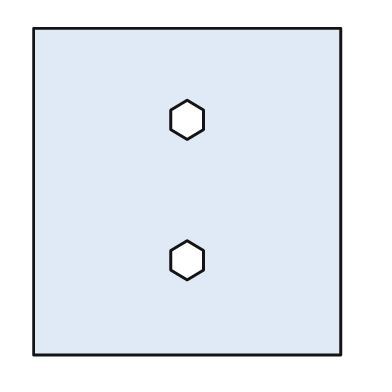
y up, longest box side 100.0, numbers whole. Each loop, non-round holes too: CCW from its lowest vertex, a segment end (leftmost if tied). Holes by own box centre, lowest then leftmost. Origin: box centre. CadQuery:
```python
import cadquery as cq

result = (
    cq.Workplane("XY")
    .moveTo(-47.0, -50.0)
    .lineTo(47.0, -50.0)
    .lineTo(47.0, 50.0)
    .lineTo(-47.0, 50.0)
    .close()
    .moveTo(0.0, -27.0)
    .lineTo(5.0, -24.0)
    .lineTo(5.0, -18.0)
    .lineTo(0.0, -15.0)
    .lineTo(-5.0, -18.0)
    .lineTo(-5.0, -24.0)
    .close()
    .moveTo(0.0, 16.0)
    .lineTo(5.0, 19.0)
    .lineTo(5.0, 25.0)
    .lineTo(0.0, 28.0)
    .lineTo(-5.0, 25.0)
    .lineTo(-5.0, 19.0)
    .close()
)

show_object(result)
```